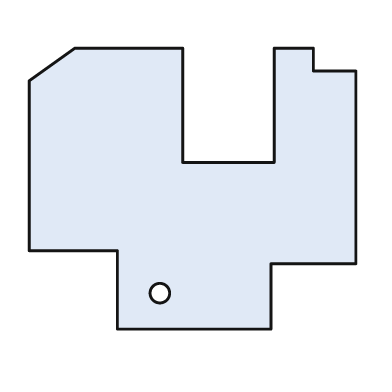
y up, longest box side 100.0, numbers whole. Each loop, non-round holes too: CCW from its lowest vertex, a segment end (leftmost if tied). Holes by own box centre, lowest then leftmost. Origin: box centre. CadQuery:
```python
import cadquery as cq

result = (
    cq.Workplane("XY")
    .moveTo(-23.0, -43.0)
    .lineTo(24.0, -43.0)
    .lineTo(24.0, -23.0)
    .lineTo(50.0, -23.0)
    .lineTo(50.0, 36.0)
    .lineTo(37.0, 36.0)
    .lineTo(37.0, 43.0)
    .lineTo(25.0, 43.0)
    .lineTo(25.0, 8.0)
    .lineTo(-3.0, 8.0)
    .lineTo(-3.0, 43.0)
    .lineTo(-36.0, 43.0)
    .lineTo(-50.0, 33.0)
    .lineTo(-50.0, -19.0)
    .lineTo(-23.0, -19.0)
    .close()
    .moveTo(-10.0, -32.0)
    .circle(3.0)
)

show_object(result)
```